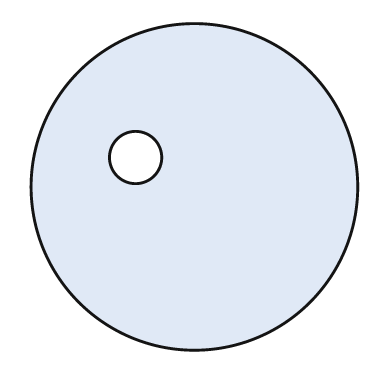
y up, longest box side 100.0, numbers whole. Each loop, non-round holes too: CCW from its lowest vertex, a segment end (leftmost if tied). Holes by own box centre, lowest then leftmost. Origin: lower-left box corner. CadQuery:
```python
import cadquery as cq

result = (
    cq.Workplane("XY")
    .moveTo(50.0, 50.0)
    .circle(50.0)
    .moveTo(32.0, 59.0)
    .circle(8.0)
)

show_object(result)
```